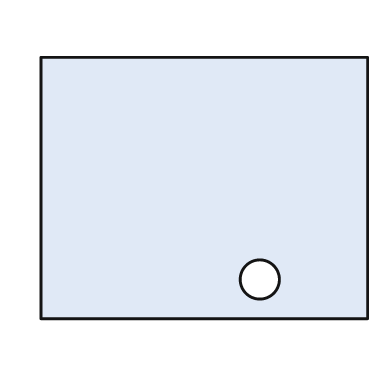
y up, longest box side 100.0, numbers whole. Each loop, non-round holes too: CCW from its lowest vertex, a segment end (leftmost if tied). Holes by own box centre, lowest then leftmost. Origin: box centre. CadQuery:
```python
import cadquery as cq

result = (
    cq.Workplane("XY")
    .moveTo(-50.0, -40.0)
    .lineTo(50.0, -40.0)
    .lineTo(50.0, 40.0)
    .lineTo(-50.0, 40.0)
    .close()
    .moveTo(17.0, -28.0)
    .circle(6.0)
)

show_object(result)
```